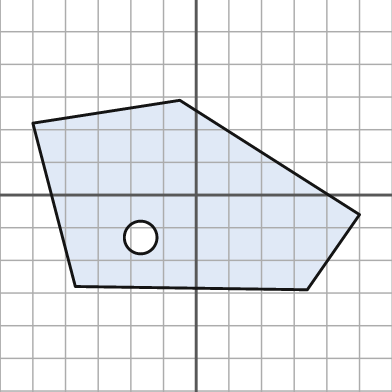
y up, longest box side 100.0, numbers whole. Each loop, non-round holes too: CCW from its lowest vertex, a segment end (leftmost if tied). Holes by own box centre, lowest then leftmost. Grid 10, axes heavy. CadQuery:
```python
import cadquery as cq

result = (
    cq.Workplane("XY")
    .moveTo(34.0, -29.0)
    .lineTo(50.0, -6.0)
    .lineTo(-5.0, 29.0)
    .lineTo(-50.0, 22.0)
    .lineTo(-37.0, -28.0)
    .close()
    .moveTo(-17.0, -13.0)
    .circle(5.0)
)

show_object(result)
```